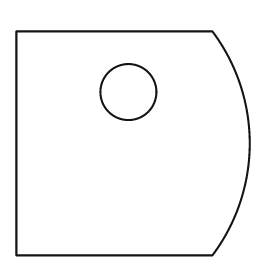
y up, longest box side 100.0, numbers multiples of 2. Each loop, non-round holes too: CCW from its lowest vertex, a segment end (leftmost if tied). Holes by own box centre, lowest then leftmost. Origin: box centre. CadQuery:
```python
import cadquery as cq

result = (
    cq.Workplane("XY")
    .moveTo(-50.0, -48.0)
    .lineTo(34.0, -48.0)
    .threePointArc((50.0, 0.0), (34.0, 48.0))
    .lineTo(-50.0, 48.0)
    .close()
    .moveTo(-2.0, 22.0)
    .circle(12.0)
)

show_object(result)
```